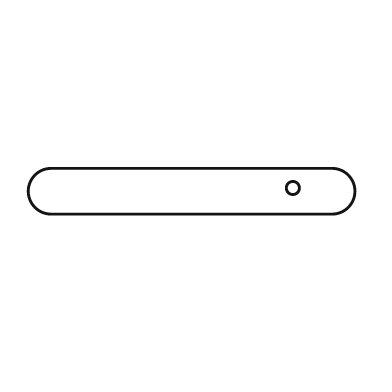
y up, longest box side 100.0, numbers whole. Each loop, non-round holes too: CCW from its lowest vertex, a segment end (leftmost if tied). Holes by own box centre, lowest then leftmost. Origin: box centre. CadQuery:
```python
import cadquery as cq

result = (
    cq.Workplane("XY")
    .moveTo(-43.0, -7.0)
    .lineTo(43.0, -7.0)
    .threePointArc((50.0, 0.0), (43.0, 7.0))
    .lineTo(-43.0, 7.0)
    .threePointArc((-50.0, 0.0), (-43.0, -7.0))
    .close()
    .moveTo(31.0, 1.0)
    .circle(2.0)
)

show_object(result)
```